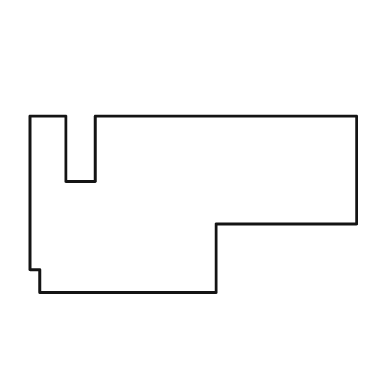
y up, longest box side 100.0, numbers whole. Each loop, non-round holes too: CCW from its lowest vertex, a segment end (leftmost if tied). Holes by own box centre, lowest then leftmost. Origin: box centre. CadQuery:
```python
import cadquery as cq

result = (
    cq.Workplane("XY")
    .moveTo(-47.0, -27.0)
    .lineTo(7.0, -27.0)
    .lineTo(7.0, -6.0)
    .lineTo(50.0, -6.0)
    .lineTo(50.0, 27.0)
    .lineTo(-30.0, 27.0)
    .lineTo(-30.0, 7.0)
    .lineTo(-39.0, 7.0)
    .lineTo(-39.0, 27.0)
    .lineTo(-50.0, 27.0)
    .lineTo(-50.0, -20.0)
    .lineTo(-47.0, -20.0)
    .close()
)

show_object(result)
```